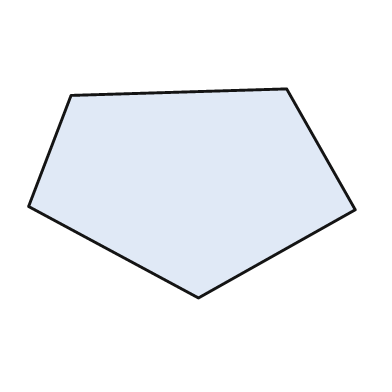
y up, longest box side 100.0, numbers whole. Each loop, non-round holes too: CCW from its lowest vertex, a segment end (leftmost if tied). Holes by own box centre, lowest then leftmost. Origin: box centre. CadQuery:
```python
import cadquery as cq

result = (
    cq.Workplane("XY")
    .moveTo(2.0, -32.0)
    .lineTo(50.0, -5.0)
    .lineTo(29.0, 32.0)
    .lineTo(-37.0, 30.0)
    .lineTo(-50.0, -4.0)
    .close()
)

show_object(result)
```